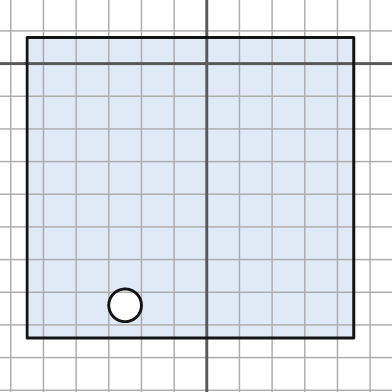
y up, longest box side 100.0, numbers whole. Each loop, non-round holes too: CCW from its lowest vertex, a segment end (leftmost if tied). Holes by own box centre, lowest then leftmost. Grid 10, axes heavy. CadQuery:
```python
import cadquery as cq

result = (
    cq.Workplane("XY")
    .moveTo(-55.0, -84.0)
    .lineTo(45.0, -84.0)
    .lineTo(45.0, 8.0)
    .lineTo(-55.0, 8.0)
    .close()
    .moveTo(-25.0, -74.0)
    .circle(5.0)
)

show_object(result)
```